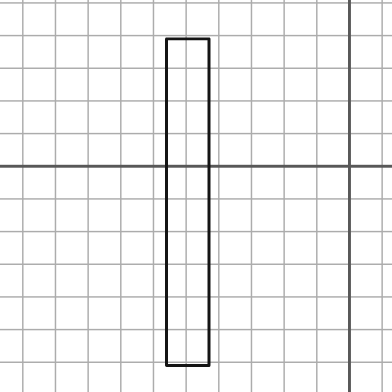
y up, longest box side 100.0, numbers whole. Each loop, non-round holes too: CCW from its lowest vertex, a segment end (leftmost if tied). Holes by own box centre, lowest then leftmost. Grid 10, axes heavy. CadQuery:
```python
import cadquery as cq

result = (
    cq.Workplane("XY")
    .moveTo(-56.0, -61.0)
    .lineTo(-43.0, -61.0)
    .lineTo(-43.0, 39.0)
    .lineTo(-56.0, 39.0)
    .close()
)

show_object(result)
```